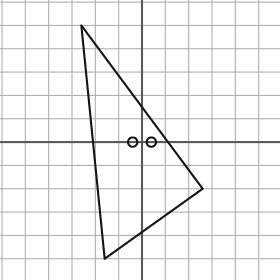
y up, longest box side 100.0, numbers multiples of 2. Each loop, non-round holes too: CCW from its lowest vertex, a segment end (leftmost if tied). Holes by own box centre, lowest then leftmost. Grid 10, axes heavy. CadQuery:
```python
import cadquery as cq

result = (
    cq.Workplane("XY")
    .moveTo(-16.0, -50.0)
    .lineTo(26.0, -20.0)
    .lineTo(-26.0, 50.0)
    .close()
    .moveTo(-4.0, 0.0)
    .circle(2.0)
    .moveTo(4.0, 0.0)
    .circle(2.0)
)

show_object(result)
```